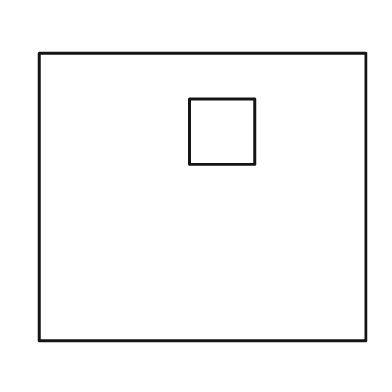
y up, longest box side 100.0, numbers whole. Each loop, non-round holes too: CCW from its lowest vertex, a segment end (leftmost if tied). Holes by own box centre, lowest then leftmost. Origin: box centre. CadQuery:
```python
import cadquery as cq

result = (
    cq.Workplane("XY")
    .moveTo(-50.0, -44.0)
    .lineTo(50.0, -44.0)
    .lineTo(50.0, 44.0)
    .lineTo(-50.0, 44.0)
    .close()
    .moveTo(-4.0, 10.0)
    .lineTo(16.0, 10.0)
    .lineTo(16.0, 30.0)
    .lineTo(-4.0, 30.0)
    .close()
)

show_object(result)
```